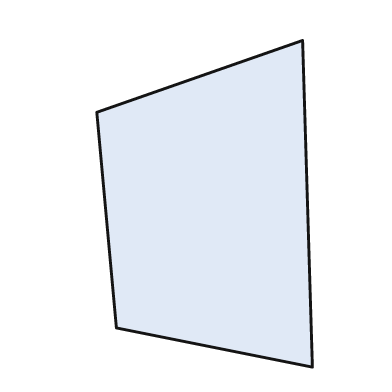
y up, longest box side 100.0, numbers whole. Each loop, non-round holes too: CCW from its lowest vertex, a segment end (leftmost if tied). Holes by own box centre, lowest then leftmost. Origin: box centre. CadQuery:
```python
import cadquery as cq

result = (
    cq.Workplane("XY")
    .moveTo(33.0, -50.0)
    .lineTo(30.0, 50.0)
    .lineTo(-33.0, 28.0)
    .lineTo(-27.0, -38.0)
    .close()
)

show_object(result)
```